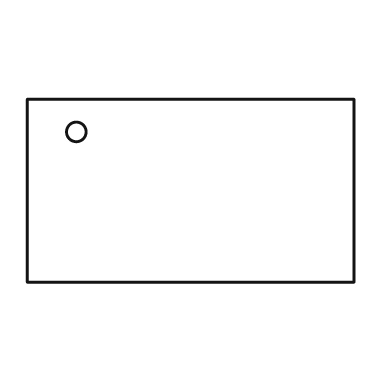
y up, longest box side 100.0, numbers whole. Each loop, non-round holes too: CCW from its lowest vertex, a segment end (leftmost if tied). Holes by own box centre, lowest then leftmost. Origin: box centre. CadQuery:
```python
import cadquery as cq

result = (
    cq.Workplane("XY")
    .moveTo(-50.0, -28.0)
    .lineTo(50.0, -28.0)
    .lineTo(50.0, 28.0)
    .lineTo(-50.0, 28.0)
    .close()
    .moveTo(-35.0, 18.0)
    .circle(3.0)
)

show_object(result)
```